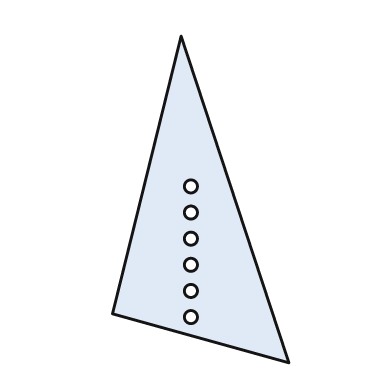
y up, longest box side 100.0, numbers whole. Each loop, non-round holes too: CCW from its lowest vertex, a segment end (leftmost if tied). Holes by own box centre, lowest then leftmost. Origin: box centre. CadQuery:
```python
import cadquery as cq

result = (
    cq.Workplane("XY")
    .moveTo(27.0, -50.0)
    .lineTo(-6.0, 50.0)
    .lineTo(-27.0, -35.0)
    .close()
    .moveTo(-3.0, -36.0)
    .circle(2.0)
    .moveTo(-3.0, -28.0)
    .circle(2.0)
    .moveTo(-3.0, -20.0)
    .circle(2.0)
    .moveTo(-3.0, -12.0)
    .circle(2.0)
    .moveTo(-3.0, -4.0)
    .circle(2.0)
    .moveTo(-3.0, 4.0)
    .circle(2.0)
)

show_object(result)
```